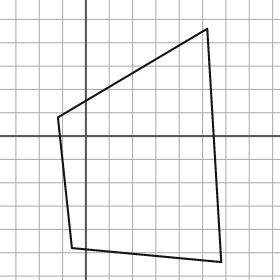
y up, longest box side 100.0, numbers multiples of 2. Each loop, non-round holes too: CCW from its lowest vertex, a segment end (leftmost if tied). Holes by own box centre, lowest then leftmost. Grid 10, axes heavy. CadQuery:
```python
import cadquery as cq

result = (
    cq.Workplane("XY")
    .moveTo(58.0, -54.0)
    .lineTo(52.0, 46.0)
    .lineTo(-12.0, 8.0)
    .lineTo(-6.0, -48.0)
    .close()
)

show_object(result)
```